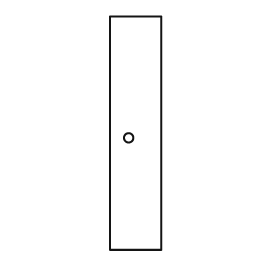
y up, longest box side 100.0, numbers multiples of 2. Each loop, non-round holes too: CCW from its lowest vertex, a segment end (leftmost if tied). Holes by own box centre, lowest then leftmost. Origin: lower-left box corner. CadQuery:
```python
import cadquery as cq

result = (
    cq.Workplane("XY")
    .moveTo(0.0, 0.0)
    .lineTo(22.0, 0.0)
    .lineTo(22.0, 100.0)
    .lineTo(0.0, 100.0)
    .close()
    .moveTo(8.0, 48.0)
    .circle(2.0)
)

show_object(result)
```